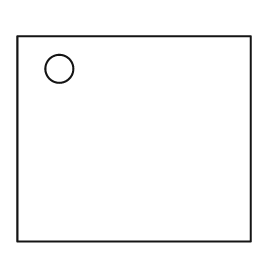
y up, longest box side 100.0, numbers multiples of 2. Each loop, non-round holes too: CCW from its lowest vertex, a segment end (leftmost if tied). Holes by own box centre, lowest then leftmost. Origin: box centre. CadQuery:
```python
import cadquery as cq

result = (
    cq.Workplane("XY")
    .moveTo(-50.0, -44.0)
    .lineTo(50.0, -44.0)
    .lineTo(50.0, 44.0)
    .lineTo(-50.0, 44.0)
    .close()
    .moveTo(-32.0, 30.0)
    .circle(6.0)
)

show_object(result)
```